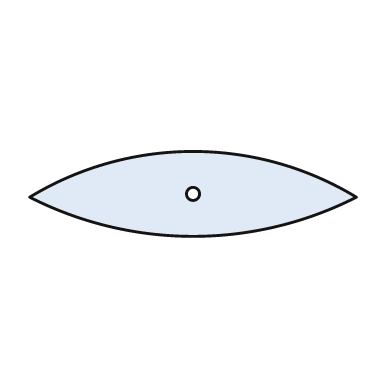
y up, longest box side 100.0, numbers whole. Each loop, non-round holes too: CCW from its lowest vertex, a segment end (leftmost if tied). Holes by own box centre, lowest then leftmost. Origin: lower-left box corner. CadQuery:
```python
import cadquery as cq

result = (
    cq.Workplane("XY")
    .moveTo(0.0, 12.0)
    .threePointArc((50.0, 0.0), (100.0, 12.0))
    .threePointArc((50.0, 26.0), (0.0, 12.0))
    .close()
    .moveTo(50.0, 13.0)
    .circle(2.0)
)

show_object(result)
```